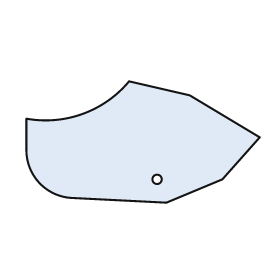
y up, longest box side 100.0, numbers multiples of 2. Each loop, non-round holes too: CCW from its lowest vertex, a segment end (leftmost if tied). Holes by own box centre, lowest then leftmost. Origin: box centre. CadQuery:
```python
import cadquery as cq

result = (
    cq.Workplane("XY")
    .moveTo(10.0, -26.0)
    .lineTo(34.0, -16.0)
    .lineTo(50.0, 2.0)
    .lineTo(20.0, 20.0)
    .lineTo(-6.0, 26.0)
    .threePointArc((-26.0, 12.0), (-50.0, 10.0))
    .lineTo(-50.0, -4.0)
    .threePointArc((-44.0, -18.0), (-30.0, -24.0))
    .close()
    .moveTo(6.0, -16.0)
    .circle(2.0)
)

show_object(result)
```